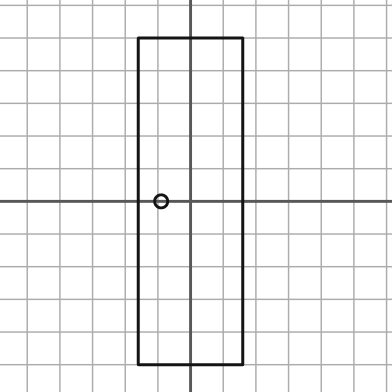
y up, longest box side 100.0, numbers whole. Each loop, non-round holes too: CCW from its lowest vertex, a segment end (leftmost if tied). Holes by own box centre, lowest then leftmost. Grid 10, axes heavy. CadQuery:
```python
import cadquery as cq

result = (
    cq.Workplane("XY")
    .moveTo(-16.0, -50.0)
    .lineTo(16.0, -50.0)
    .lineTo(16.0, 50.0)
    .lineTo(-16.0, 50.0)
    .close()
    .moveTo(-9.0, 0.0)
    .circle(2.0)
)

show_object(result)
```